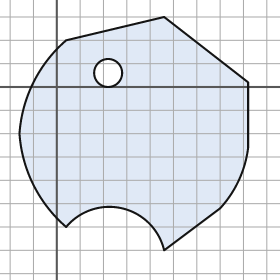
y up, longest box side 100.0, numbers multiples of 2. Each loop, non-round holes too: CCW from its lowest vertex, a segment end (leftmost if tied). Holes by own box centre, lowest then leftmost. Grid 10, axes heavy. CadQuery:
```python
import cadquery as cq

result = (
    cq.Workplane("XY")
    .moveTo(46.0, -70.0)
    .lineTo(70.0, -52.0)
    .threePointArc((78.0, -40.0), (82.0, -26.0))
    .lineTo(82.0, 2.0)
    .lineTo(46.0, 30.0)
    .lineTo(4.0, 20.0)
    .threePointArc((-10.0, 2.0), (-16.0, -20.0))
    .threePointArc((-10.0, -42.0), (4.0, -60.0))
    .threePointArc((28.0, -52.0), (46.0, -70.0))
    .close()
    .moveTo(22.0, 6.0)
    .circle(6.0)
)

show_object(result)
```